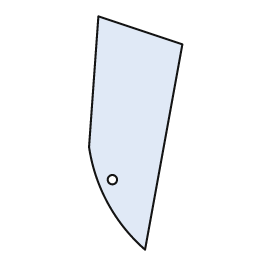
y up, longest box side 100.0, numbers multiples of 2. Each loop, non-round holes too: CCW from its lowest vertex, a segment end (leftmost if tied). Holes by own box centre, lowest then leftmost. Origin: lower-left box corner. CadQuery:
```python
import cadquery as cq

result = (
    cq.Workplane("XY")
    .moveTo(24.0, 0.0)
    .lineTo(40.0, 88.0)
    .lineTo(4.0, 100.0)
    .lineTo(0.0, 44.0)
    .threePointArc((8.0, 20.0), (24.0, 0.0))
    .close()
    .moveTo(10.0, 30.0)
    .circle(2.0)
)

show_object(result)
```